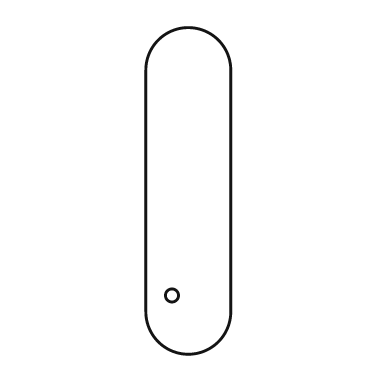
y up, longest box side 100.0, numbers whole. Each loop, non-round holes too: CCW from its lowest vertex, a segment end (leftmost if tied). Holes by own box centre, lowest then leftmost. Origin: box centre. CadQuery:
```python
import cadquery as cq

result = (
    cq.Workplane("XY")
    .moveTo(-13.0, -37.0)
    .threePointArc((0.0, -50.0), (13.0, -37.0))
    .lineTo(13.0, 37.0)
    .threePointArc((0.0, 50.0), (-13.0, 37.0))
    .close()
    .moveTo(-5.0, -32.0)
    .circle(2.0)
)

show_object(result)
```